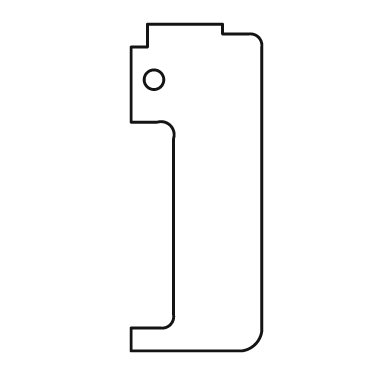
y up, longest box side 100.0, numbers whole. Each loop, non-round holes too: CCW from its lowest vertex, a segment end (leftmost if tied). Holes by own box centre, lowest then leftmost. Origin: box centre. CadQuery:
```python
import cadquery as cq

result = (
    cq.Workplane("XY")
    .moveTo(-20.0, -50.0)
    .lineTo(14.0, -50.0)
    .threePointArc((18.0, -48.0), (20.0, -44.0))
    .lineTo(20.0, 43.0)
    .threePointArc((19.0, 46.0), (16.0, 47.0))
    .lineTo(8.0, 47.0)
    .lineTo(8.0, 50.0)
    .lineTo(-15.0, 50.0)
    .lineTo(-15.0, 43.0)
    .lineTo(-20.0, 43.0)
    .lineTo(-20.0, 20.0)
    .lineTo(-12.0, 20.0)
    .threePointArc((-8.0, 19.0), (-7.0, 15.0))
    .lineTo(-7.0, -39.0)
    .threePointArc((-8.0, -42.0), (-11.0, -43.0))
    .lineTo(-20.0, -43.0)
    .close()
    .moveTo(-13.0, 33.0)
    .circle(3.0)
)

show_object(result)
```